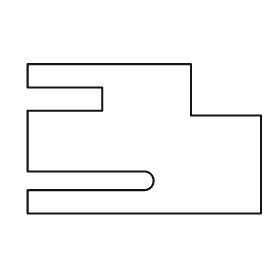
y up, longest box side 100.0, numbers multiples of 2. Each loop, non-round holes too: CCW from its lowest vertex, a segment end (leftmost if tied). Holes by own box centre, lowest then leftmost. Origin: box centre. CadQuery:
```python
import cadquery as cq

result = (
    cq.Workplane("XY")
    .moveTo(-50.0, -32.0)
    .lineTo(50.0, -32.0)
    .lineTo(50.0, 10.0)
    .lineTo(20.0, 10.0)
    .lineTo(20.0, 32.0)
    .lineTo(-50.0, 32.0)
    .lineTo(-50.0, 22.0)
    .lineTo(-18.0, 22.0)
    .lineTo(-18.0, 12.0)
    .lineTo(-50.0, 12.0)
    .lineTo(-50.0, -14.0)
    .lineTo(0.0, -14.0)
    .threePointArc((4.0, -18.0), (0.0, -22.0))
    .lineTo(-50.0, -22.0)
    .close()
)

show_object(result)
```